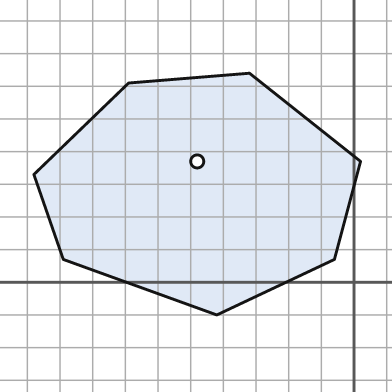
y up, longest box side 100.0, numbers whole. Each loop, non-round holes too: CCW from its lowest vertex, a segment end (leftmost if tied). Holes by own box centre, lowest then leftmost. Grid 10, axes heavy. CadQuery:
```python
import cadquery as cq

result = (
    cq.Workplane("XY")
    .moveTo(-42.0, -10.0)
    .lineTo(-6.0, 7.0)
    .lineTo(2.0, 37.0)
    .lineTo(-32.0, 64.0)
    .lineTo(-69.0, 61.0)
    .lineTo(-98.0, 33.0)
    .lineTo(-89.0, 7.0)
    .close()
    .moveTo(-48.0, 37.0)
    .circle(2.0)
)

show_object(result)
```